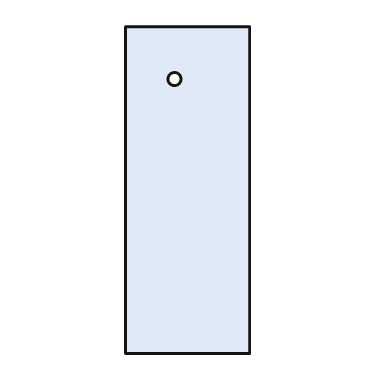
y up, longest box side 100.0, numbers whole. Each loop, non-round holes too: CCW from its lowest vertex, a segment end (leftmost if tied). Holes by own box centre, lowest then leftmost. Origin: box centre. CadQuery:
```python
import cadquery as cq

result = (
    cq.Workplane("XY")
    .moveTo(-19.0, -50.0)
    .lineTo(19.0, -50.0)
    .lineTo(19.0, 50.0)
    .lineTo(-19.0, 50.0)
    .close()
    .moveTo(-4.0, 34.0)
    .circle(2.0)
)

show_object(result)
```